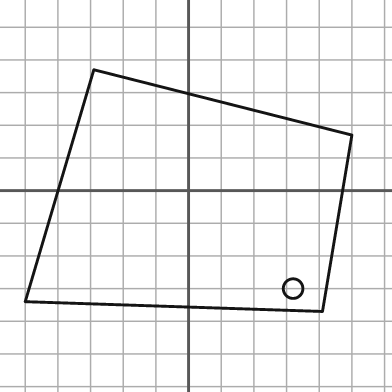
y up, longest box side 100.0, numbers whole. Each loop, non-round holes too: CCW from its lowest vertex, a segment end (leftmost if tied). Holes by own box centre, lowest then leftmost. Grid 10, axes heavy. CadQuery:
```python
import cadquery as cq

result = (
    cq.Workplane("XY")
    .moveTo(41.0, -37.0)
    .lineTo(50.0, 17.0)
    .lineTo(-29.0, 37.0)
    .lineTo(-50.0, -34.0)
    .close()
    .moveTo(32.0, -30.0)
    .circle(3.0)
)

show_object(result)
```